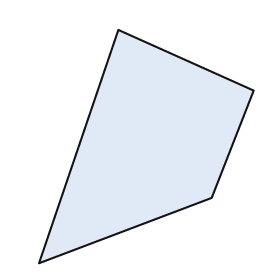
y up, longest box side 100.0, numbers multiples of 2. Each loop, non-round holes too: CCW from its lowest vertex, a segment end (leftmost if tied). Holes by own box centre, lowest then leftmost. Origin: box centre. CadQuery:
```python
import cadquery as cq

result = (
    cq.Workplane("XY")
    .moveTo(-46.0, -50.0)
    .lineTo(28.0, -22.0)
    .lineTo(46.0, 24.0)
    .lineTo(-12.0, 50.0)
    .close()
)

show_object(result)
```